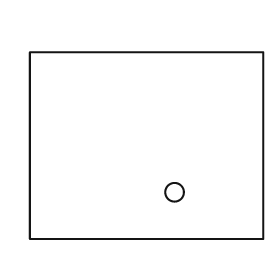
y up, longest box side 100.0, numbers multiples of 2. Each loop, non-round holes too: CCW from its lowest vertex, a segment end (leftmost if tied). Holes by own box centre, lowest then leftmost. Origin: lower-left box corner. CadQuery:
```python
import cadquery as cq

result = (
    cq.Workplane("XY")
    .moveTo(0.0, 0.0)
    .lineTo(100.0, 0.0)
    .lineTo(100.0, 80.0)
    .lineTo(0.0, 80.0)
    .close()
    .moveTo(62.0, 20.0)
    .circle(4.0)
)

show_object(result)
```